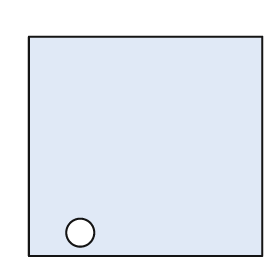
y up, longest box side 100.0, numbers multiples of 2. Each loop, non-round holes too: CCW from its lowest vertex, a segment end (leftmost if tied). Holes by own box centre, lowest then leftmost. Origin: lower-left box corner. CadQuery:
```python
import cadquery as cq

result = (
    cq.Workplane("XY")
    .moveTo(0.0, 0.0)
    .lineTo(100.0, 0.0)
    .lineTo(100.0, 94.0)
    .lineTo(0.0, 94.0)
    .close()
    .moveTo(22.0, 10.0)
    .circle(6.0)
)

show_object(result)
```